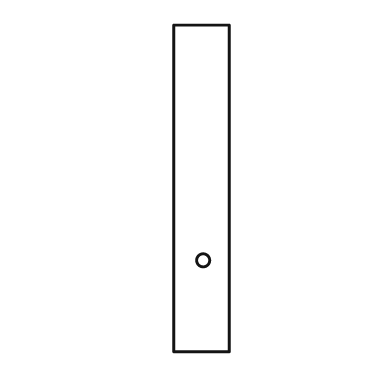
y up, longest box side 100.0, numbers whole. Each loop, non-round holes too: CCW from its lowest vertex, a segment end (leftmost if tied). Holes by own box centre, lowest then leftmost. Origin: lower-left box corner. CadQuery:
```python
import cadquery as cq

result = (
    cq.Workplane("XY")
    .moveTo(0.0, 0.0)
    .lineTo(17.0, 0.0)
    .lineTo(17.0, 100.0)
    .lineTo(0.0, 100.0)
    .close()
    .moveTo(9.0, 28.0)
    .circle(2.0)
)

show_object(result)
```